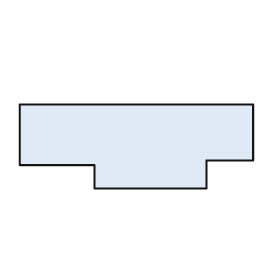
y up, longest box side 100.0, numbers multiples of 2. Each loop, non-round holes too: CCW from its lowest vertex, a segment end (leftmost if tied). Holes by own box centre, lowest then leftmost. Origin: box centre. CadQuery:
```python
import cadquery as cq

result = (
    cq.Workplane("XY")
    .moveTo(-18.0, -18.0)
    .lineTo(30.0, -18.0)
    .lineTo(30.0, -6.0)
    .lineTo(50.0, -6.0)
    .lineTo(50.0, 18.0)
    .lineTo(-50.0, 18.0)
    .lineTo(-50.0, -8.0)
    .lineTo(-18.0, -8.0)
    .close()
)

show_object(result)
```